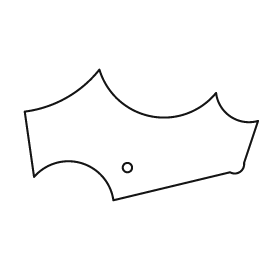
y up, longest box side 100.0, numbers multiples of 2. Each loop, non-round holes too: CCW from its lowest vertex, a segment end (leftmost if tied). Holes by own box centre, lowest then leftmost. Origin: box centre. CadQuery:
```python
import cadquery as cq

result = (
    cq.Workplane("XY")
    .moveTo(-12.0, -28.0)
    .lineTo(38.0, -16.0)
    .threePointArc((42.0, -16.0), (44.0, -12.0))
    .lineTo(50.0, 6.0)
    .threePointArc((38.0, 8.0), (32.0, 18.0))
    .threePointArc((4.0, 8.0), (-18.0, 28.0))
    .threePointArc((-32.0, 16.0), (-50.0, 10.0))
    .lineTo(-46.0, -18.0)
    .threePointArc((-26.0, -12.0), (-12.0, -28.0))
    .close()
    .moveTo(-6.0, -14.0)
    .circle(2.0)
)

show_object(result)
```